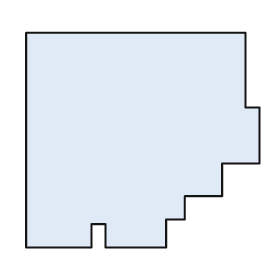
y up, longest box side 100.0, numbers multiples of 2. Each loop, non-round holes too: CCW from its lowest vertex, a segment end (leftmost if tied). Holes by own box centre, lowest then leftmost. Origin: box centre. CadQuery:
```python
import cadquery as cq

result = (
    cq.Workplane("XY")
    .moveTo(-50.0, -46.0)
    .lineTo(-22.0, -46.0)
    .lineTo(-22.0, -36.0)
    .lineTo(-16.0, -36.0)
    .lineTo(-16.0, -46.0)
    .lineTo(10.0, -46.0)
    .lineTo(10.0, -34.0)
    .lineTo(18.0, -34.0)
    .lineTo(18.0, -24.0)
    .lineTo(34.0, -24.0)
    .lineTo(34.0, -10.0)
    .lineTo(50.0, -10.0)
    .lineTo(50.0, 14.0)
    .lineTo(44.0, 14.0)
    .lineTo(44.0, 46.0)
    .lineTo(-50.0, 46.0)
    .close()
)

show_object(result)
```